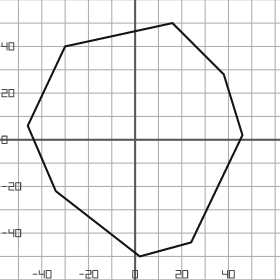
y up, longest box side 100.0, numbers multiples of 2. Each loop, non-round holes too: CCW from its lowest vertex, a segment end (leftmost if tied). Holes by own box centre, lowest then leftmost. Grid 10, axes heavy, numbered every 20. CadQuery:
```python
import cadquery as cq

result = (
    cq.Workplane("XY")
    .moveTo(2.0, -50.0)
    .lineTo(24.0, -44.0)
    .lineTo(46.0, 2.0)
    .lineTo(38.0, 28.0)
    .lineTo(16.0, 50.0)
    .lineTo(-30.0, 40.0)
    .lineTo(-46.0, 6.0)
    .lineTo(-34.0, -22.0)
    .close()
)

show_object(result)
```